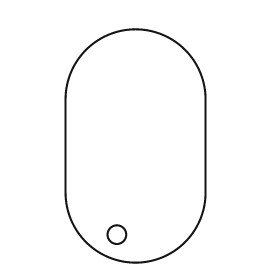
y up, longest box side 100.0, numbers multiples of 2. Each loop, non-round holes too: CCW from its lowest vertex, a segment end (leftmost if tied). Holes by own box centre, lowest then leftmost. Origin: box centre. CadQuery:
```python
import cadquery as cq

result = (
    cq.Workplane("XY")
    .moveTo(-30.0, -20.0)
    .threePointArc((0.0, -50.0), (30.0, -20.0))
    .lineTo(30.0, 20.0)
    .threePointArc((0.0, 50.0), (-30.0, 20.0))
    .close()
    .moveTo(-8.0, -38.0)
    .circle(4.0)
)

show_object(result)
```